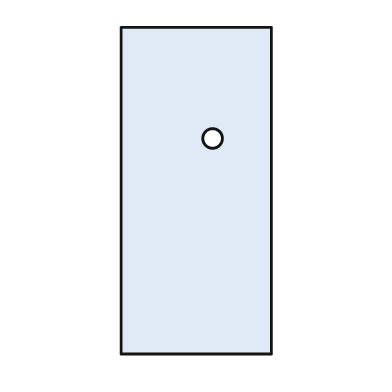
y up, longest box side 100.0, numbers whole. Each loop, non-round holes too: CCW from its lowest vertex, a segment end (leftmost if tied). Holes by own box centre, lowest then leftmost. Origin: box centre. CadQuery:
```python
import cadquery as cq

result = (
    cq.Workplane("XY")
    .moveTo(-23.0, -50.0)
    .lineTo(23.0, -50.0)
    .lineTo(23.0, 50.0)
    .lineTo(-23.0, 50.0)
    .close()
    .moveTo(5.0, 16.0)
    .circle(3.0)
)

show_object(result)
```